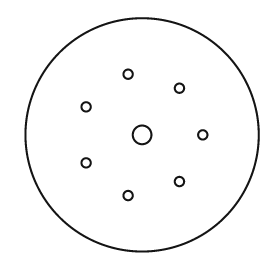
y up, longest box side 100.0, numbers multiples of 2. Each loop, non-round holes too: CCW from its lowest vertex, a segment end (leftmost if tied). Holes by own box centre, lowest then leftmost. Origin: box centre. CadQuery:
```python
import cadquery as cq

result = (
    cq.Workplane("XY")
    .moveTo(0.0, 0.0)
    .circle(50.0)
    .moveTo(-6.0, -26.0)
    .circle(2.0)
    .moveTo(16.0, -20.0)
    .circle(2.0)
    .moveTo(-24.0, -12.0)
    .circle(2.0)
    .moveTo(0.0, 0.0)
    .circle(4.0)
    .moveTo(26.0, 0.0)
    .circle(2.0)
    .moveTo(-24.0, 12.0)
    .circle(2.0)
    .moveTo(16.0, 20.0)
    .circle(2.0)
    .moveTo(-6.0, 26.0)
    .circle(2.0)
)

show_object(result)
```